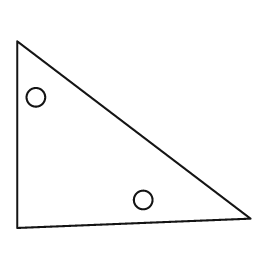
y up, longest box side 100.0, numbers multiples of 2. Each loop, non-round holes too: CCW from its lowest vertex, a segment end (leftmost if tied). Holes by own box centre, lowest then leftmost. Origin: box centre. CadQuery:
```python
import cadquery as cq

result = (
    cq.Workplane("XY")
    .moveTo(-50.0, -40.0)
    .lineTo(50.0, -36.0)
    .lineTo(-50.0, 40.0)
    .close()
    .moveTo(4.0, -28.0)
    .circle(4.0)
    .moveTo(-42.0, 16.0)
    .circle(4.0)
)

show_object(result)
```